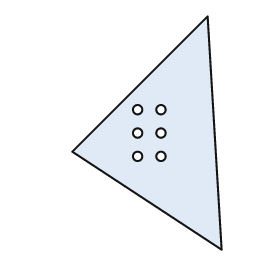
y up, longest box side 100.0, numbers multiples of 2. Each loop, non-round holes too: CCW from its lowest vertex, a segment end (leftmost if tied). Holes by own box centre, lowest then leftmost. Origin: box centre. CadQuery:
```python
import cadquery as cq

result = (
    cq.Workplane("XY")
    .moveTo(32.0, -50.0)
    .lineTo(26.0, 50.0)
    .lineTo(-32.0, -8.0)
    .close()
    .moveTo(-4.0, -10.0)
    .circle(2.0)
    .moveTo(6.0, -10.0)
    .circle(2.0)
    .moveTo(-4.0, 0.0)
    .circle(2.0)
    .moveTo(6.0, 0.0)
    .circle(2.0)
    .moveTo(-4.0, 10.0)
    .circle(2.0)
    .moveTo(6.0, 10.0)
    .circle(2.0)
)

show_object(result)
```